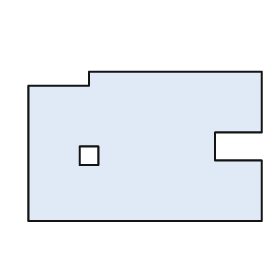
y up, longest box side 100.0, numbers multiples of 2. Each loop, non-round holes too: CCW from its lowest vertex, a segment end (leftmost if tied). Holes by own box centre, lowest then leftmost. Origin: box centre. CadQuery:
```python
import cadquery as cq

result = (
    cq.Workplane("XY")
    .moveTo(-50.0, -32.0)
    .lineTo(50.0, -32.0)
    .lineTo(50.0, -6.0)
    .lineTo(30.0, -6.0)
    .lineTo(30.0, 6.0)
    .lineTo(50.0, 6.0)
    .lineTo(50.0, 32.0)
    .lineTo(-24.0, 32.0)
    .lineTo(-24.0, 26.0)
    .lineTo(-50.0, 26.0)
    .close()
    .moveTo(-28.0, -8.0)
    .lineTo(-20.0, -8.0)
    .lineTo(-20.0, 0.0)
    .lineTo(-28.0, 0.0)
    .close()
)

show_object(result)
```